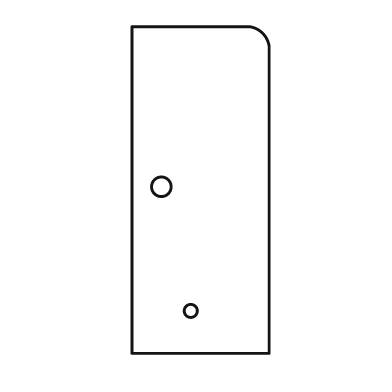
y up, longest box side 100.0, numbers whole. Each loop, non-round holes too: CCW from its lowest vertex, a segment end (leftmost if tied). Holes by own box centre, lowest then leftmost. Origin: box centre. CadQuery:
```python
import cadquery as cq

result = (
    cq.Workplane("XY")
    .moveTo(-21.0, -50.0)
    .lineTo(21.0, -50.0)
    .lineTo(21.0, 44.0)
    .threePointArc((19.0, 48.0), (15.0, 50.0))
    .lineTo(-21.0, 50.0)
    .close()
    .moveTo(-3.0, -37.0)
    .circle(2.0)
    .moveTo(-12.0, 1.0)
    .circle(3.0)
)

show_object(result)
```